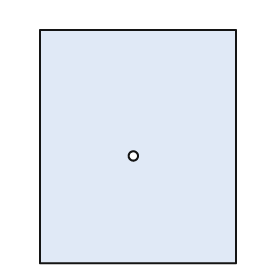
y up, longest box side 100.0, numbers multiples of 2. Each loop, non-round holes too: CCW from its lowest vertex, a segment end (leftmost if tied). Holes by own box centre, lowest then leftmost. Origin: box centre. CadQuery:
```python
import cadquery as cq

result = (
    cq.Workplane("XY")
    .moveTo(-42.0, -50.0)
    .lineTo(42.0, -50.0)
    .lineTo(42.0, 50.0)
    .lineTo(-42.0, 50.0)
    .close()
    .moveTo(-2.0, -4.0)
    .circle(2.0)
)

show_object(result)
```